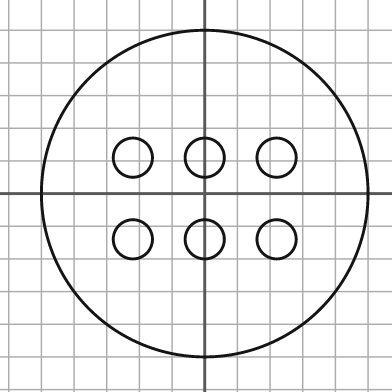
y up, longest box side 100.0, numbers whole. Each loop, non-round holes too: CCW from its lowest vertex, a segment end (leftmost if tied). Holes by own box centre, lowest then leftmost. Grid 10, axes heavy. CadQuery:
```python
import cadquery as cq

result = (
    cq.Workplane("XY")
    .moveTo(0.0, 0.0)
    .circle(50.0)
    .moveTo(-22.0, -14.0)
    .circle(6.0)
    .moveTo(0.0, -14.0)
    .circle(6.0)
    .moveTo(22.0, -14.0)
    .circle(6.0)
    .moveTo(-22.0, 11.0)
    .circle(6.0)
    .moveTo(0.0, 11.0)
    .circle(6.0)
    .moveTo(22.0, 11.0)
    .circle(6.0)
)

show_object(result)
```